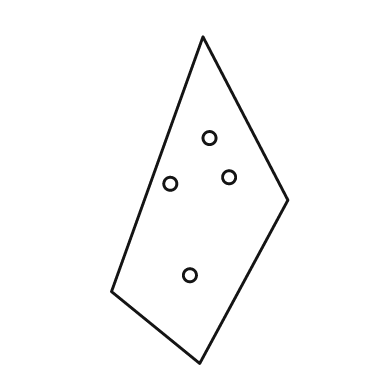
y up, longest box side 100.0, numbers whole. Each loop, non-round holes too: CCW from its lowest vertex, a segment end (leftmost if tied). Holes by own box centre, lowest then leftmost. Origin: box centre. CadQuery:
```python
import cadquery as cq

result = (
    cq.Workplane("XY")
    .moveTo(0.0, -50.0)
    .lineTo(27.0, 0.0)
    .lineTo(1.0, 50.0)
    .lineTo(-27.0, -28.0)
    .close()
    .moveTo(-3.0, -23.0)
    .circle(2.0)
    .moveTo(-9.0, 5.0)
    .circle(2.0)
    .moveTo(9.0, 7.0)
    .circle(2.0)
    .moveTo(3.0, 19.0)
    .circle(2.0)
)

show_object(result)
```